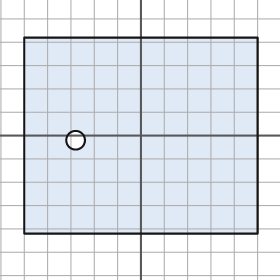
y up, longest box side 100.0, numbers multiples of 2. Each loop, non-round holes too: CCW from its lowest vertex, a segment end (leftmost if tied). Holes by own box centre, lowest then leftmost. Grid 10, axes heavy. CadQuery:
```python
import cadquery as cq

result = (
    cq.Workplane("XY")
    .moveTo(-50.0, -42.0)
    .lineTo(50.0, -42.0)
    .lineTo(50.0, 42.0)
    .lineTo(-50.0, 42.0)
    .close()
    .moveTo(-28.0, -2.0)
    .circle(4.0)
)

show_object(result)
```